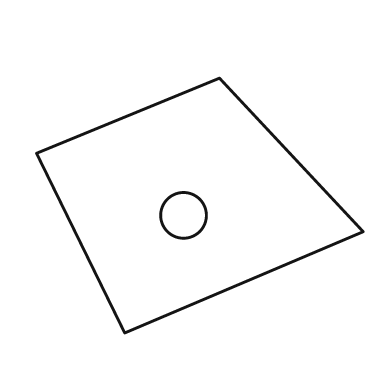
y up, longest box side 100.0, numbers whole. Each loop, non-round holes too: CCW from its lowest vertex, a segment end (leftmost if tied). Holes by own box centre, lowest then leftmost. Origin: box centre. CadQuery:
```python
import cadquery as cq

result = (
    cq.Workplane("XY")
    .moveTo(-23.0, -39.0)
    .lineTo(50.0, -8.0)
    .lineTo(6.0, 39.0)
    .lineTo(-50.0, 16.0)
    .close()
    .moveTo(-5.0, -3.0)
    .circle(7.0)
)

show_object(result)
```